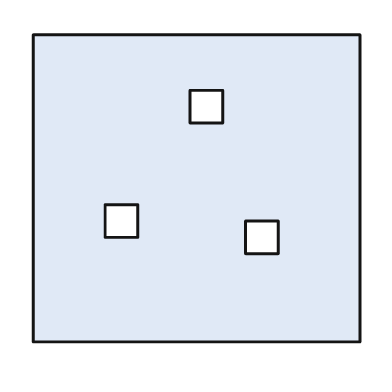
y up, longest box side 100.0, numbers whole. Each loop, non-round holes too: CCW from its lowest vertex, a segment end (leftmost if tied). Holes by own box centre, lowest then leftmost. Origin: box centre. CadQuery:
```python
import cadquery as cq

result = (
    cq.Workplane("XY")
    .moveTo(-50.0, -47.0)
    .lineTo(50.0, -47.0)
    .lineTo(50.0, 47.0)
    .lineTo(-50.0, 47.0)
    .close()
    .moveTo(15.0, -20.0)
    .lineTo(25.0, -20.0)
    .lineTo(25.0, -10.0)
    .lineTo(15.0, -10.0)
    .close()
    .moveTo(-28.0, -15.0)
    .lineTo(-18.0, -15.0)
    .lineTo(-18.0, -5.0)
    .lineTo(-28.0, -5.0)
    .close()
    .moveTo(-2.0, 20.0)
    .lineTo(8.0, 20.0)
    .lineTo(8.0, 30.0)
    .lineTo(-2.0, 30.0)
    .close()
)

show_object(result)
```